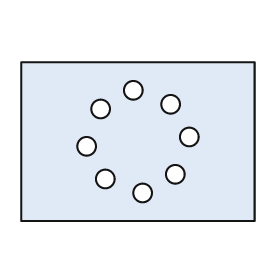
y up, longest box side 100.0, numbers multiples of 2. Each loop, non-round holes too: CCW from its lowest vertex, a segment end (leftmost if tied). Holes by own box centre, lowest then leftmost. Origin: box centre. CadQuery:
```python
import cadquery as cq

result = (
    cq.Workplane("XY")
    .moveTo(-50.0, -34.0)
    .lineTo(50.0, -34.0)
    .lineTo(50.0, 34.0)
    .lineTo(-50.0, 34.0)
    .close()
    .moveTo(2.0, -22.0)
    .circle(4.0)
    .moveTo(-14.0, -16.0)
    .circle(4.0)
    .moveTo(16.0, -14.0)
    .circle(4.0)
    .moveTo(-22.0, -2.0)
    .circle(4.0)
    .moveTo(22.0, 2.0)
    .circle(4.0)
    .moveTo(-16.0, 14.0)
    .circle(4.0)
    .moveTo(14.0, 16.0)
    .circle(4.0)
    .moveTo(-2.0, 22.0)
    .circle(4.0)
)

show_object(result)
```